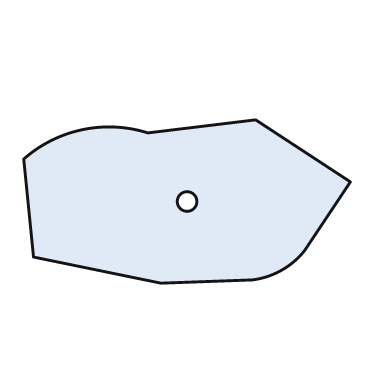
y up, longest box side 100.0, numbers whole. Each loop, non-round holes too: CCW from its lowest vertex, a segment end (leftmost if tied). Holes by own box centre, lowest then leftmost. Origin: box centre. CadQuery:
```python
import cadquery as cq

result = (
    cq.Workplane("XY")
    .moveTo(-8.0, -25.0)
    .lineTo(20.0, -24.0)
    .threePointArc((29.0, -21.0), (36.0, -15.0))
    .lineTo(50.0, 6.0)
    .lineTo(21.0, 25.0)
    .lineTo(-12.0, 21.0)
    .threePointArc((-32.0, 22.0), (-50.0, 13.0))
    .lineTo(-47.0, -17.0)
    .close()
    .moveTo(0.0, 0.0)
    .circle(3.0)
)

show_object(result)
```